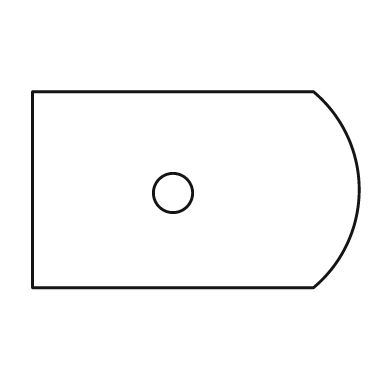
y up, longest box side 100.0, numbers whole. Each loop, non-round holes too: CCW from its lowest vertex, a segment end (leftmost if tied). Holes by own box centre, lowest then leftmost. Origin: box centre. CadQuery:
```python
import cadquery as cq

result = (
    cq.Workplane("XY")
    .moveTo(-50.0, -30.0)
    .lineTo(36.0, -30.0)
    .threePointArc((50.0, 0.0), (36.0, 30.0))
    .lineTo(-50.0, 30.0)
    .close()
    .moveTo(-7.0, -1.0)
    .circle(6.0)
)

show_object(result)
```